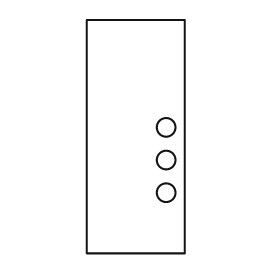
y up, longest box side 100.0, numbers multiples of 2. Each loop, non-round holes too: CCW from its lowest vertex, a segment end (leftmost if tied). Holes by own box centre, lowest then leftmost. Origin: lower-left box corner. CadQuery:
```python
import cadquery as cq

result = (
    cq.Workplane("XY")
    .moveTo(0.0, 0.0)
    .lineTo(42.0, 0.0)
    .lineTo(42.0, 100.0)
    .lineTo(0.0, 100.0)
    .close()
    .moveTo(34.0, 26.0)
    .circle(4.0)
    .moveTo(34.0, 40.0)
    .circle(4.0)
    .moveTo(34.0, 54.0)
    .circle(4.0)
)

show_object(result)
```